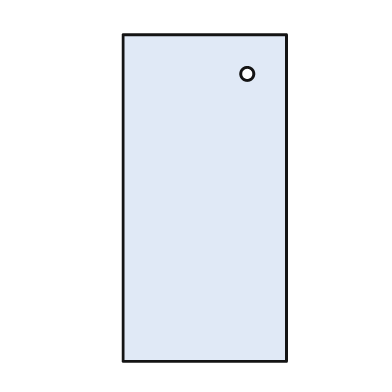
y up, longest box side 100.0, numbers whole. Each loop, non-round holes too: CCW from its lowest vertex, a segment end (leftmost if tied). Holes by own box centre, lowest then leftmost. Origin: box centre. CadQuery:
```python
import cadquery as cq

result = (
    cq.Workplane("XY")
    .moveTo(-25.0, -50.0)
    .lineTo(25.0, -50.0)
    .lineTo(25.0, 50.0)
    .lineTo(-25.0, 50.0)
    .close()
    .moveTo(13.0, 38.0)
    .circle(2.0)
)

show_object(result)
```